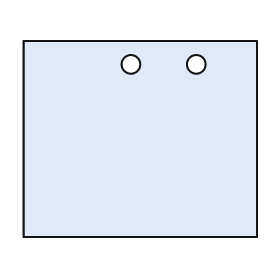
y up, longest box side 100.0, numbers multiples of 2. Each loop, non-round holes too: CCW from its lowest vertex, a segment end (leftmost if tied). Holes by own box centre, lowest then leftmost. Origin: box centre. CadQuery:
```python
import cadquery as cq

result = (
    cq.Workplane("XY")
    .moveTo(-50.0, -42.0)
    .lineTo(50.0, -42.0)
    .lineTo(50.0, 42.0)
    .lineTo(-50.0, 42.0)
    .close()
    .moveTo(-4.0, 32.0)
    .circle(4.0)
    .moveTo(24.0, 32.0)
    .circle(4.0)
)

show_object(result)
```